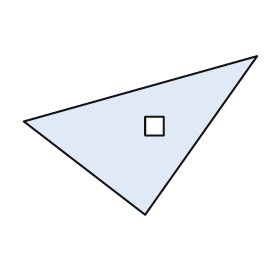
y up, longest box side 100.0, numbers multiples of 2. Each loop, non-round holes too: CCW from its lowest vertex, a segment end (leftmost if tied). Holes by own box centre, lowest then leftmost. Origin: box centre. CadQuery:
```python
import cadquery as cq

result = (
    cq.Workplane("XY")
    .moveTo(2.0, -34.0)
    .lineTo(50.0, 34.0)
    .lineTo(-50.0, 6.0)
    .close()
    .moveTo(2.0, 0.0)
    .lineTo(10.0, 0.0)
    .lineTo(10.0, 8.0)
    .lineTo(2.0, 8.0)
    .close()
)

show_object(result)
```